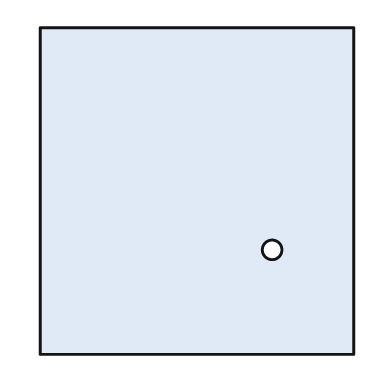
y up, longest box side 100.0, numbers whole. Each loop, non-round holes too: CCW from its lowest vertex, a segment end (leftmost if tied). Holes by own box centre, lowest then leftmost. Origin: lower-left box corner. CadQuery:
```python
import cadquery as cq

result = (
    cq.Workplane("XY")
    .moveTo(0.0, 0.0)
    .lineTo(96.0, 0.0)
    .lineTo(96.0, 100.0)
    .lineTo(0.0, 100.0)
    .close()
    .moveTo(71.0, 32.0)
    .circle(3.0)
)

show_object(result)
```